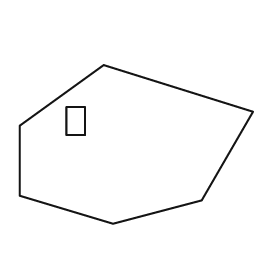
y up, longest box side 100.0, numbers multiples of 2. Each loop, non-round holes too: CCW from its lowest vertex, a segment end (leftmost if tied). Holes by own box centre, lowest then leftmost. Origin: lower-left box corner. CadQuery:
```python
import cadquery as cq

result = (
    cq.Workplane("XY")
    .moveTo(40.0, 0.0)
    .lineTo(78.0, 10.0)
    .lineTo(100.0, 48.0)
    .lineTo(36.0, 68.0)
    .lineTo(0.0, 42.0)
    .lineTo(0.0, 12.0)
    .close()
    .moveTo(20.0, 38.0)
    .lineTo(28.0, 38.0)
    .lineTo(28.0, 50.0)
    .lineTo(20.0, 50.0)
    .close()
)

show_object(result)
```